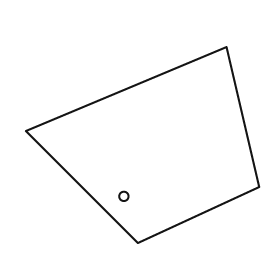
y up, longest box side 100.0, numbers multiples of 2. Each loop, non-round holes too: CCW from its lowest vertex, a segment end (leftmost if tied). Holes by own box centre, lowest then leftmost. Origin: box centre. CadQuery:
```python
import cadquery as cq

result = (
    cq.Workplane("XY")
    .moveTo(-2.0, -42.0)
    .lineTo(50.0, -18.0)
    .lineTo(36.0, 42.0)
    .lineTo(-50.0, 6.0)
    .close()
    .moveTo(-8.0, -22.0)
    .circle(2.0)
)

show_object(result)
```